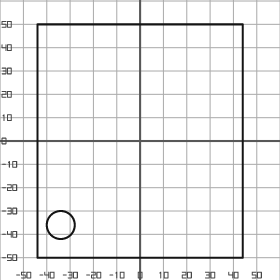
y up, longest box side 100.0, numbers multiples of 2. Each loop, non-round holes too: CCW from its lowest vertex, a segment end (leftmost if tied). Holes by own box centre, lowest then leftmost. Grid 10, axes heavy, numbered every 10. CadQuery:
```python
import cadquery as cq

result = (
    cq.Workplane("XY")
    .moveTo(-44.0, -50.0)
    .lineTo(44.0, -50.0)
    .lineTo(44.0, 50.0)
    .lineTo(-44.0, 50.0)
    .close()
    .moveTo(-34.0, -36.0)
    .circle(6.0)
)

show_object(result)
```